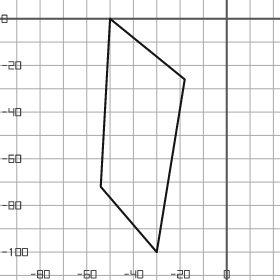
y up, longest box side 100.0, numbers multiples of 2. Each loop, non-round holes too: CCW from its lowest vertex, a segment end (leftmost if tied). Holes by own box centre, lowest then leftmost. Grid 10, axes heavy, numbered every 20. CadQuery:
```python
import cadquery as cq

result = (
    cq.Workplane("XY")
    .moveTo(-30.0, -100.0)
    .lineTo(-18.0, -26.0)
    .lineTo(-50.0, 0.0)
    .lineTo(-54.0, -72.0)
    .close()
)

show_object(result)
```